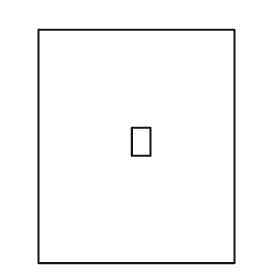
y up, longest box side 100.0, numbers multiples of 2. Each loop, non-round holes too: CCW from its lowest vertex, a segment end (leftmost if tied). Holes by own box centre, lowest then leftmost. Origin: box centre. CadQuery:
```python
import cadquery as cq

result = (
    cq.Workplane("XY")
    .moveTo(-42.0, -50.0)
    .lineTo(42.0, -50.0)
    .lineTo(42.0, 50.0)
    .lineTo(-42.0, 50.0)
    .close()
    .moveTo(-2.0, -4.0)
    .lineTo(6.0, -4.0)
    .lineTo(6.0, 8.0)
    .lineTo(-2.0, 8.0)
    .close()
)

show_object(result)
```